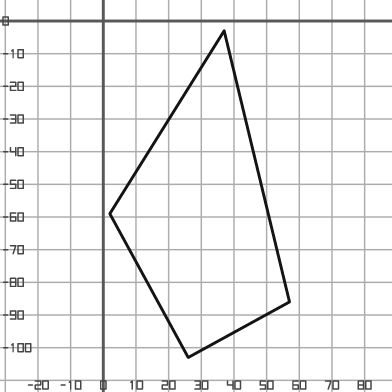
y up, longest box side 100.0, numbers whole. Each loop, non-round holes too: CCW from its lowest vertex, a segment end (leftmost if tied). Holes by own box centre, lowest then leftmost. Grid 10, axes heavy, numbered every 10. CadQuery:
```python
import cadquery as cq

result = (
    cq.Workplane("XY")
    .moveTo(26.0, -103.0)
    .lineTo(57.0, -86.0)
    .lineTo(37.0, -3.0)
    .lineTo(2.0, -59.0)
    .close()
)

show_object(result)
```